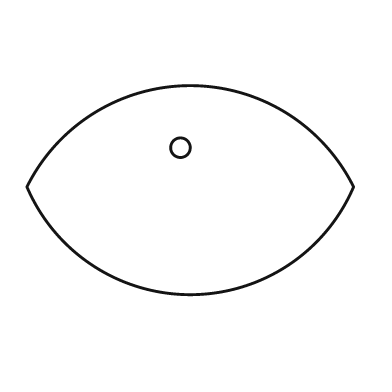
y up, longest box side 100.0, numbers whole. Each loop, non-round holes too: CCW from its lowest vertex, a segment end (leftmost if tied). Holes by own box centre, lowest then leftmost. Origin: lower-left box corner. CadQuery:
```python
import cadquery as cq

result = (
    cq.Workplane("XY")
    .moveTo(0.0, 33.0)
    .threePointArc((50.0, 0.0), (100.0, 33.0))
    .threePointArc((50.0, 64.0), (0.0, 33.0))
    .close()
    .moveTo(47.0, 45.0)
    .circle(3.0)
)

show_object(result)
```